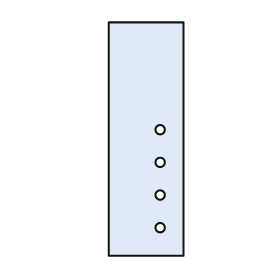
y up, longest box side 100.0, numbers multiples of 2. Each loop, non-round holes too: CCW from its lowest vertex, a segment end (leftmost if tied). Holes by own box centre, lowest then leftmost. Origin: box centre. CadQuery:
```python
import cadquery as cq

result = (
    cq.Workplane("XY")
    .moveTo(-16.0, -50.0)
    .lineTo(16.0, -50.0)
    .lineTo(16.0, 50.0)
    .lineTo(-16.0, 50.0)
    .close()
    .moveTo(6.0, -38.0)
    .circle(2.0)
    .moveTo(6.0, -24.0)
    .circle(2.0)
    .moveTo(6.0, -10.0)
    .circle(2.0)
    .moveTo(6.0, 4.0)
    .circle(2.0)
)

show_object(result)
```